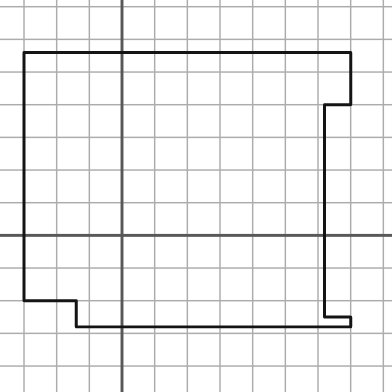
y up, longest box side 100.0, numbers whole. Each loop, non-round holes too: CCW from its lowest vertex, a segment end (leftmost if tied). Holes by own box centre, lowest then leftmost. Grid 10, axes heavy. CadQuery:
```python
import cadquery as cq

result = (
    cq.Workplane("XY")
    .moveTo(-14.0, -28.0)
    .lineTo(70.0, -28.0)
    .lineTo(70.0, -25.0)
    .lineTo(62.0, -25.0)
    .lineTo(62.0, 40.0)
    .lineTo(70.0, 40.0)
    .lineTo(70.0, 56.0)
    .lineTo(-30.0, 56.0)
    .lineTo(-30.0, -20.0)
    .lineTo(-14.0, -20.0)
    .close()
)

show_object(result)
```